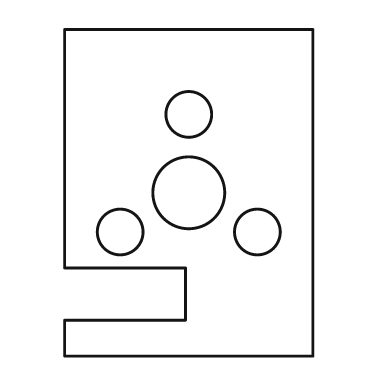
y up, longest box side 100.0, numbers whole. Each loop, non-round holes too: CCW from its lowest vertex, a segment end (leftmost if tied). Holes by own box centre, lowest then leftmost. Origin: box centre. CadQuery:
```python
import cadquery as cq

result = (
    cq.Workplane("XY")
    .moveTo(-38.0, -50.0)
    .lineTo(38.0, -50.0)
    .lineTo(38.0, 50.0)
    .lineTo(-38.0, 50.0)
    .lineTo(-38.0, -23.0)
    .lineTo(-1.0, -23.0)
    .lineTo(-1.0, -39.0)
    .lineTo(-38.0, -39.0)
    .close()
    .moveTo(-21.0, -12.0)
    .circle(7.0)
    .moveTo(21.0, -12.0)
    .circle(7.0)
    .moveTo(0.0, 0.0)
    .circle(11.0)
    .moveTo(0.0, 24.0)
    .circle(7.0)
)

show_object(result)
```